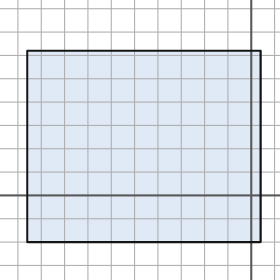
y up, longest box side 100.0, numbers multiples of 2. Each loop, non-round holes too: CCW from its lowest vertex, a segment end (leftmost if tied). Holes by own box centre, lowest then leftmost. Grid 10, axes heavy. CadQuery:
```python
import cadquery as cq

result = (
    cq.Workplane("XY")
    .moveTo(-96.0, -20.0)
    .lineTo(4.0, -20.0)
    .lineTo(4.0, 62.0)
    .lineTo(-96.0, 62.0)
    .close()
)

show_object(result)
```